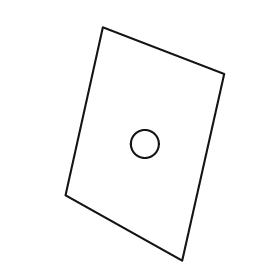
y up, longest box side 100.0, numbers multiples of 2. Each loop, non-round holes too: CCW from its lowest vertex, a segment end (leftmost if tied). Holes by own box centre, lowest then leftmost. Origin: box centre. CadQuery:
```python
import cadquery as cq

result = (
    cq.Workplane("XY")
    .moveTo(16.0, -50.0)
    .lineTo(34.0, 30.0)
    .lineTo(-18.0, 50.0)
    .lineTo(-34.0, -22.0)
    .close()
    .moveTo(0.0, 0.0)
    .circle(6.0)
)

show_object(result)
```